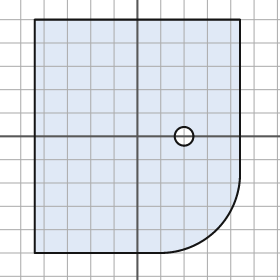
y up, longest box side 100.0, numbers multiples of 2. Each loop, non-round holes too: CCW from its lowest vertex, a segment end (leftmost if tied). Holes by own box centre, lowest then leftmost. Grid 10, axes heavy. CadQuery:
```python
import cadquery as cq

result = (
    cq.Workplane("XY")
    .moveTo(-44.0, -50.0)
    .lineTo(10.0, -50.0)
    .threePointArc((34.0, -40.0), (44.0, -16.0))
    .lineTo(44.0, 50.0)
    .lineTo(-44.0, 50.0)
    .close()
    .moveTo(20.0, 0.0)
    .circle(4.0)
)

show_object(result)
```